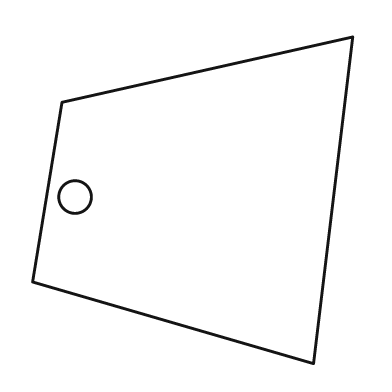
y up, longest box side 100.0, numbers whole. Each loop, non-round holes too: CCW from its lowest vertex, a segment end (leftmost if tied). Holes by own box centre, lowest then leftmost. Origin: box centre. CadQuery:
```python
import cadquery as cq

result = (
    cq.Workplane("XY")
    .moveTo(37.0, -50.0)
    .lineTo(49.0, 50.0)
    .lineTo(-40.0, 30.0)
    .lineTo(-49.0, -25.0)
    .close()
    .moveTo(-36.0, 1.0)
    .circle(5.0)
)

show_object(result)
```